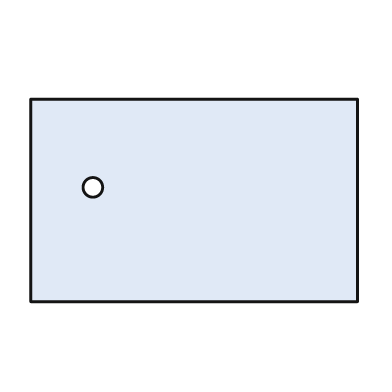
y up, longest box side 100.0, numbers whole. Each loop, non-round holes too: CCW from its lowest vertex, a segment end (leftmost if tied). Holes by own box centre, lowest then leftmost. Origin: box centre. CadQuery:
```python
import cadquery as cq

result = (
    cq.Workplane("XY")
    .moveTo(-50.0, -31.0)
    .lineTo(50.0, -31.0)
    .lineTo(50.0, 31.0)
    .lineTo(-50.0, 31.0)
    .close()
    .moveTo(-31.0, 4.0)
    .circle(3.0)
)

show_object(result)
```